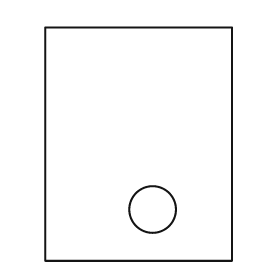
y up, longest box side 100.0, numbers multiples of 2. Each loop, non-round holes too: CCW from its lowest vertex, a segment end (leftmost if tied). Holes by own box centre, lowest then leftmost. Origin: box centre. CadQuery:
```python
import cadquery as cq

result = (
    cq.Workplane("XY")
    .moveTo(-40.0, -50.0)
    .lineTo(40.0, -50.0)
    .lineTo(40.0, 50.0)
    .lineTo(-40.0, 50.0)
    .close()
    .moveTo(6.0, -28.0)
    .circle(10.0)
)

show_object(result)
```